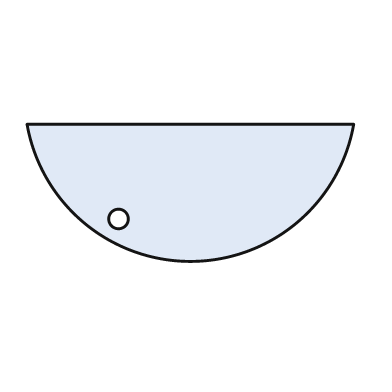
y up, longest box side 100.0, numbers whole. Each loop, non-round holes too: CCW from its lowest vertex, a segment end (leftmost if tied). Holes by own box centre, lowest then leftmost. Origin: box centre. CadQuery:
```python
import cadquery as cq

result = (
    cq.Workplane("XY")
    .moveTo(-50.0, 21.0)
    .threePointArc((0.0, -21.0), (50.0, 21.0))
    .close()
    .moveTo(-22.0, -8.0)
    .circle(3.0)
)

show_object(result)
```